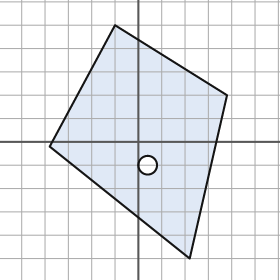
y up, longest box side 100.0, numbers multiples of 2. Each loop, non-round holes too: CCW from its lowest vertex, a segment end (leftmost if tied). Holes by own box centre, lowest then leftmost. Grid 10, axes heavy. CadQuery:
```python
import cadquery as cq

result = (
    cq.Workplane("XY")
    .moveTo(22.0, -50.0)
    .lineTo(38.0, 20.0)
    .lineTo(-10.0, 50.0)
    .lineTo(-38.0, -2.0)
    .close()
    .moveTo(4.0, -10.0)
    .circle(4.0)
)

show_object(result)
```